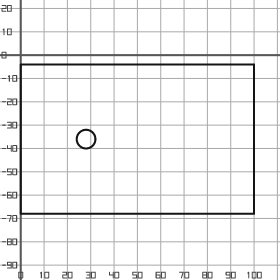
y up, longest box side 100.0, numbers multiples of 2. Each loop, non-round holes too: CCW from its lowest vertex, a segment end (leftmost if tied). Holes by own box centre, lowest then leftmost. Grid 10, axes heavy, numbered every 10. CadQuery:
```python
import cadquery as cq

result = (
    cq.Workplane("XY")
    .moveTo(0.0, -68.0)
    .lineTo(100.0, -68.0)
    .lineTo(100.0, -4.0)
    .lineTo(0.0, -4.0)
    .close()
    .moveTo(28.0, -36.0)
    .circle(4.0)
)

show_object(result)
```